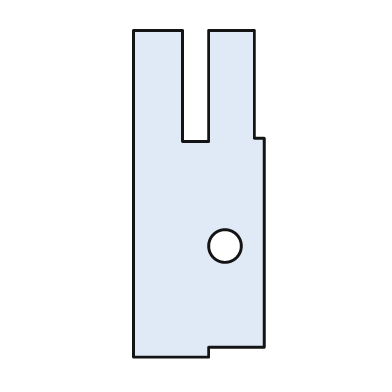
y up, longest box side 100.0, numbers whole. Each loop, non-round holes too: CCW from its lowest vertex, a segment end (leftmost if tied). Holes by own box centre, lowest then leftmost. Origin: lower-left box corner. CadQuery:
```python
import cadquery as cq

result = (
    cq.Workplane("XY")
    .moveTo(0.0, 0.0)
    .lineTo(23.0, 0.0)
    .lineTo(23.0, 3.0)
    .lineTo(40.0, 3.0)
    .lineTo(40.0, 67.0)
    .lineTo(37.0, 67.0)
    .lineTo(37.0, 100.0)
    .lineTo(23.0, 100.0)
    .lineTo(23.0, 66.0)
    .lineTo(15.0, 66.0)
    .lineTo(15.0, 100.0)
    .lineTo(0.0, 100.0)
    .close()
    .moveTo(28.0, 34.0)
    .circle(5.0)
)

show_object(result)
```